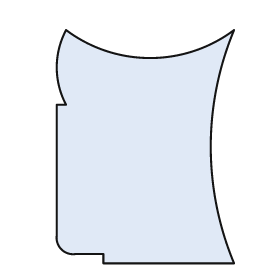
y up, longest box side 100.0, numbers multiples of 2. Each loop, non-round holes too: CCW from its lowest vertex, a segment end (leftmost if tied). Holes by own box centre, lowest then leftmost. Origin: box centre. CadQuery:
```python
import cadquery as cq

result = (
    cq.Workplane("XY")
    .moveTo(-18.0, -50.0)
    .lineTo(38.0, -50.0)
    .threePointArc((28.0, 0.0), (38.0, 50.0))
    .threePointArc((2.0, 38.0), (-34.0, 50.0))
    .threePointArc((-38.0, 34.0), (-34.0, 18.0))
    .lineTo(-38.0, 18.0)
    .lineTo(-38.0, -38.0)
    .threePointArc((-36.0, -44.0), (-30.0, -46.0))
    .lineTo(-18.0, -46.0)
    .close()
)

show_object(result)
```